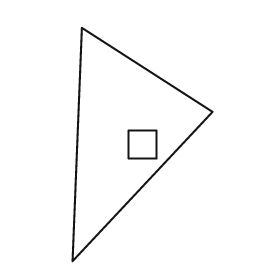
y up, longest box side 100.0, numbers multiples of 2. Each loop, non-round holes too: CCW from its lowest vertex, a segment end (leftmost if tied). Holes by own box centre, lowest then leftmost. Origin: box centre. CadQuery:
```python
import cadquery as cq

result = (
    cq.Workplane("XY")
    .moveTo(-30.0, -50.0)
    .lineTo(30.0, 14.0)
    .lineTo(-26.0, 50.0)
    .close()
    .moveTo(-6.0, -6.0)
    .lineTo(6.0, -6.0)
    .lineTo(6.0, 6.0)
    .lineTo(-6.0, 6.0)
    .close()
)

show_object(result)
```